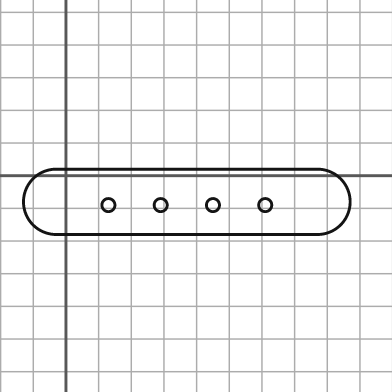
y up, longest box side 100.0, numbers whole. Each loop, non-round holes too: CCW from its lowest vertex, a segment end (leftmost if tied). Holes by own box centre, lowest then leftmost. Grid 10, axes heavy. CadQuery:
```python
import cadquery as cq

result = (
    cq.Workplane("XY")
    .moveTo(-3.0, -18.0)
    .lineTo(77.0, -18.0)
    .threePointArc((87.0, -8.0), (77.0, 2.0))
    .lineTo(-3.0, 2.0)
    .threePointArc((-13.0, -8.0), (-3.0, -18.0))
    .close()
    .moveTo(13.0, -9.0)
    .circle(2.0)
    .moveTo(29.0, -9.0)
    .circle(2.0)
    .moveTo(45.0, -9.0)
    .circle(2.0)
    .moveTo(61.0, -9.0)
    .circle(2.0)
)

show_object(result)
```